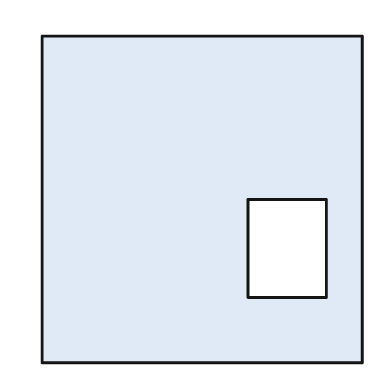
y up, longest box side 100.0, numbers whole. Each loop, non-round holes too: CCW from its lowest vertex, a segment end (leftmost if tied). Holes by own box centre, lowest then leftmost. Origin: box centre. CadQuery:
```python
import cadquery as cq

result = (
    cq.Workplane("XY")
    .moveTo(-49.0, -50.0)
    .lineTo(49.0, -50.0)
    .lineTo(49.0, 50.0)
    .lineTo(-49.0, 50.0)
    .close()
    .moveTo(14.0, -30.0)
    .lineTo(38.0, -30.0)
    .lineTo(38.0, 0.0)
    .lineTo(14.0, 0.0)
    .close()
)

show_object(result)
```